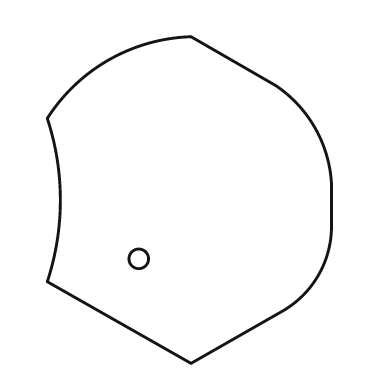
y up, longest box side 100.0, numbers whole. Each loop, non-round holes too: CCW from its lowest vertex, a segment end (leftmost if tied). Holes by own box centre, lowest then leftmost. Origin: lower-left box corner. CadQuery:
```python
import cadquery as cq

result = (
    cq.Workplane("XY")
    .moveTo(44.0, 0.0)
    .lineTo(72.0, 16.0)
    .threePointArc((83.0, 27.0), (87.0, 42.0))
    .lineTo(87.0, 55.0)
    .threePointArc((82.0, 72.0), (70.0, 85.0))
    .lineTo(44.0, 100.0)
    .threePointArc((19.0, 93.0), (0.0, 75.0))
    .threePointArc((4.0, 50.0), (0.0, 25.0))
    .close()
    .moveTo(28.0, 32.0)
    .circle(3.0)
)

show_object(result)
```